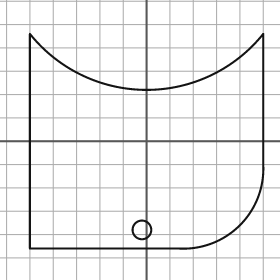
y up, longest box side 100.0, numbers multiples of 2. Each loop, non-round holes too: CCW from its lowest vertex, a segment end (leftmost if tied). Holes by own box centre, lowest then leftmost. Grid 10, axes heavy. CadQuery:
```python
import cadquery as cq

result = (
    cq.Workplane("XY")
    .moveTo(-50.0, -46.0)
    .lineTo(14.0, -46.0)
    .threePointArc((40.0, -36.0), (50.0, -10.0))
    .lineTo(50.0, 46.0)
    .threePointArc((0.0, 22.0), (-50.0, 46.0))
    .close()
    .moveTo(-2.0, -38.0)
    .circle(4.0)
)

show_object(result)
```